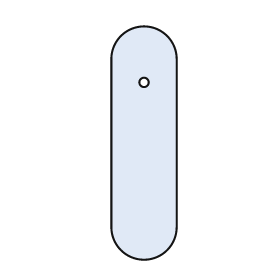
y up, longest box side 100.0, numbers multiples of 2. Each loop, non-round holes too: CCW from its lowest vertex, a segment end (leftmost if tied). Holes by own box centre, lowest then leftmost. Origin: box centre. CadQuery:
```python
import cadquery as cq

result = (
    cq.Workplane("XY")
    .moveTo(-14.0, -36.0)
    .threePointArc((0.0, -50.0), (14.0, -36.0))
    .lineTo(14.0, 36.0)
    .threePointArc((0.0, 50.0), (-14.0, 36.0))
    .close()
    .moveTo(0.0, 26.0)
    .circle(2.0)
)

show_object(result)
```